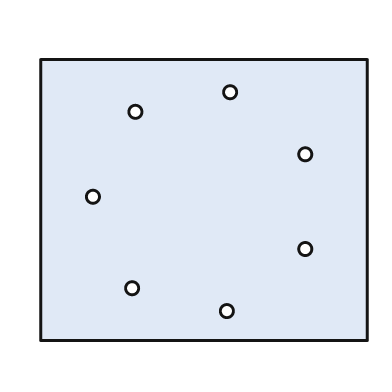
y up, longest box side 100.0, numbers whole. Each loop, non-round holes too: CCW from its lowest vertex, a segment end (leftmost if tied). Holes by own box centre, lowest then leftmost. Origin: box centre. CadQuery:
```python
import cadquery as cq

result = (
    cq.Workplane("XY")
    .moveTo(-50.0, -43.0)
    .lineTo(50.0, -43.0)
    .lineTo(50.0, 43.0)
    .lineTo(-50.0, 43.0)
    .close()
    .moveTo(7.0, -34.0)
    .circle(2.0)
    .moveTo(-22.0, -27.0)
    .circle(2.0)
    .moveTo(31.0, -15.0)
    .circle(2.0)
    .moveTo(-34.0, 1.0)
    .circle(2.0)
    .moveTo(31.0, 14.0)
    .circle(2.0)
    .moveTo(-21.0, 27.0)
    .circle(2.0)
    .moveTo(8.0, 33.0)
    .circle(2.0)
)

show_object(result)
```